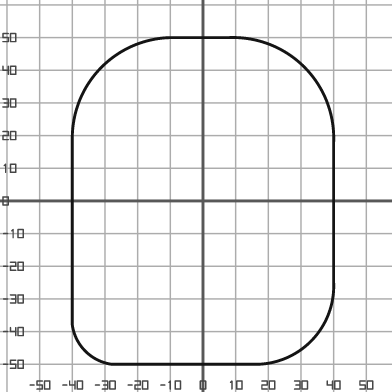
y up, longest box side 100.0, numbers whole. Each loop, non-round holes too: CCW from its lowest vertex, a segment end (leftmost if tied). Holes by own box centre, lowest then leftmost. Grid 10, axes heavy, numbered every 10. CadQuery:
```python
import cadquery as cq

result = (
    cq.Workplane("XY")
    .moveTo(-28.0, -50.0)
    .lineTo(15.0, -50.0)
    .threePointArc((33.0, -43.0), (40.0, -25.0))
    .lineTo(40.0, 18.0)
    .threePointArc((31.0, 41.0), (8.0, 50.0))
    .lineTo(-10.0, 50.0)
    .threePointArc((-31.0, 41.0), (-40.0, 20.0))
    .lineTo(-40.0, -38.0)
    .threePointArc((-36.0, -46.0), (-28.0, -50.0))
    .close()
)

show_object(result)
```